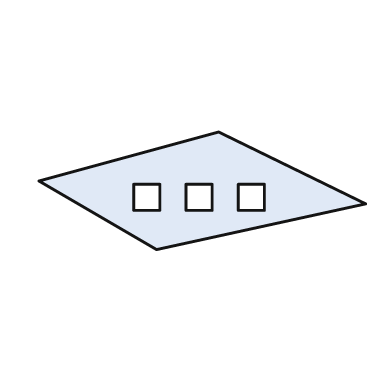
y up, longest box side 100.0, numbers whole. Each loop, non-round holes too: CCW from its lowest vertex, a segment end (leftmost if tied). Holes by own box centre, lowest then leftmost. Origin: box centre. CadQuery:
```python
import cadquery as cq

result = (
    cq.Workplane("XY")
    .moveTo(-14.0, -18.0)
    .lineTo(50.0, -4.0)
    .lineTo(5.0, 18.0)
    .lineTo(-50.0, 3.0)
    .close()
    .moveTo(-21.0, -6.0)
    .lineTo(-13.0, -6.0)
    .lineTo(-13.0, 2.0)
    .lineTo(-21.0, 2.0)
    .close()
    .moveTo(-5.0, -6.0)
    .lineTo(3.0, -6.0)
    .lineTo(3.0, 2.0)
    .lineTo(-5.0, 2.0)
    .close()
    .moveTo(11.0, -6.0)
    .lineTo(19.0, -6.0)
    .lineTo(19.0, 2.0)
    .lineTo(11.0, 2.0)
    .close()
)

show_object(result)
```